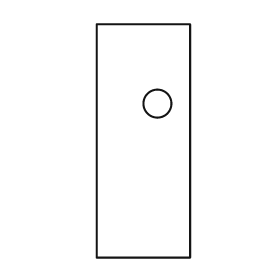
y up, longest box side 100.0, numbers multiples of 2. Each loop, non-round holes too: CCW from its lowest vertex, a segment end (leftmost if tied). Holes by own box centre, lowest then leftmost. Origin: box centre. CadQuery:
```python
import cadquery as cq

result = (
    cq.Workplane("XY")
    .moveTo(-20.0, -50.0)
    .lineTo(20.0, -50.0)
    .lineTo(20.0, 50.0)
    .lineTo(-20.0, 50.0)
    .close()
    .moveTo(6.0, 16.0)
    .circle(6.0)
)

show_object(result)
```